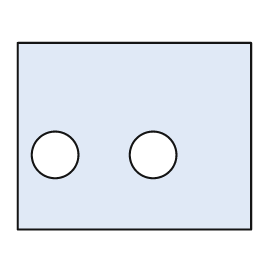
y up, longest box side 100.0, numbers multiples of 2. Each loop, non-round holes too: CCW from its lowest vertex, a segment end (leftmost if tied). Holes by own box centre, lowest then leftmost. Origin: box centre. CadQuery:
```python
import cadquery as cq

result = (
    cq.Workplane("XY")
    .moveTo(-50.0, -40.0)
    .lineTo(50.0, -40.0)
    .lineTo(50.0, 40.0)
    .lineTo(-50.0, 40.0)
    .close()
    .moveTo(-34.0, -8.0)
    .circle(10.0)
    .moveTo(8.0, -8.0)
    .circle(10.0)
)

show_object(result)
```